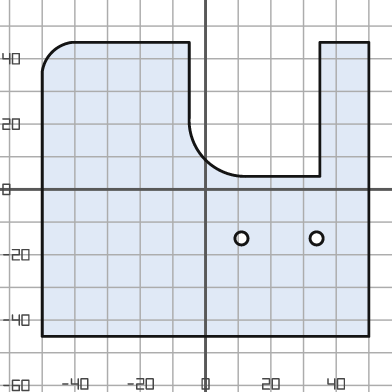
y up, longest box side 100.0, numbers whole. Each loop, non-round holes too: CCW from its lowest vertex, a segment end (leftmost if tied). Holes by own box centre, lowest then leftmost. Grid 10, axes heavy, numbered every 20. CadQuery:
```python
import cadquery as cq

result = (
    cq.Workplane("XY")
    .moveTo(-50.0, -45.0)
    .lineTo(50.0, -45.0)
    .lineTo(50.0, 45.0)
    .lineTo(35.0, 45.0)
    .lineTo(35.0, 4.0)
    .lineTo(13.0, 4.0)
    .threePointArc((0.0, 9.0), (-5.0, 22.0))
    .lineTo(-5.0, 45.0)
    .lineTo(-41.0, 45.0)
    .threePointArc((-47.0, 42.0), (-50.0, 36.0))
    .close()
    .moveTo(11.0, -15.0)
    .circle(2.0)
    .moveTo(34.0, -15.0)
    .circle(2.0)
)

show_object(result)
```